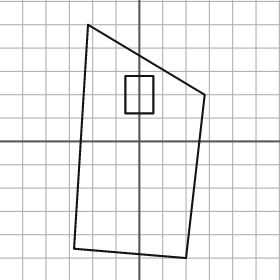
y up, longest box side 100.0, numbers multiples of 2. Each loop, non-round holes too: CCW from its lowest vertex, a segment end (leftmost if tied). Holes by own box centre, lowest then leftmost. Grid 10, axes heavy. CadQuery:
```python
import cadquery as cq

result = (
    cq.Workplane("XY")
    .moveTo(20.0, -50.0)
    .lineTo(28.0, 20.0)
    .lineTo(-22.0, 50.0)
    .lineTo(-28.0, -46.0)
    .close()
    .moveTo(-6.0, 12.0)
    .lineTo(6.0, 12.0)
    .lineTo(6.0, 28.0)
    .lineTo(-6.0, 28.0)
    .close()
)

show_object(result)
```